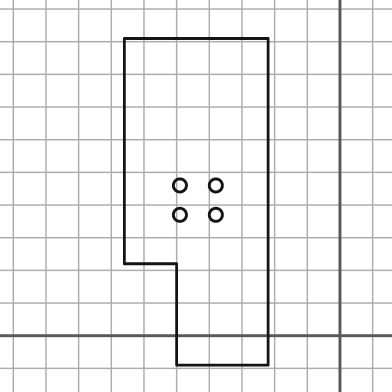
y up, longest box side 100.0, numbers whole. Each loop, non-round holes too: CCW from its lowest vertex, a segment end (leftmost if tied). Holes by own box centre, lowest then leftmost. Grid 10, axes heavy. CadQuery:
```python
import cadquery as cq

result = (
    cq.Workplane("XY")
    .moveTo(-50.0, -9.0)
    .lineTo(-22.0, -9.0)
    .lineTo(-22.0, 91.0)
    .lineTo(-66.0, 91.0)
    .lineTo(-66.0, 22.0)
    .lineTo(-50.0, 22.0)
    .close()
    .moveTo(-49.0, 37.0)
    .circle(2.0)
    .moveTo(-38.0, 37.0)
    .circle(2.0)
    .moveTo(-49.0, 46.0)
    .circle(2.0)
    .moveTo(-38.0, 46.0)
    .circle(2.0)
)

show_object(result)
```